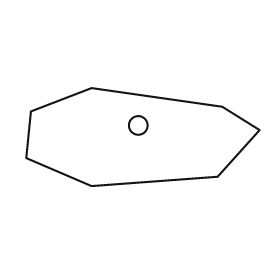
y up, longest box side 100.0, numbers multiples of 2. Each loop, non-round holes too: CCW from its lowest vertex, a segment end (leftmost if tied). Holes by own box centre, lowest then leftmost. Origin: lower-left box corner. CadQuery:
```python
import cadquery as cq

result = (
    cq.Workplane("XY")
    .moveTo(28.0, 0.0)
    .lineTo(82.0, 4.0)
    .lineTo(100.0, 24.0)
    .lineTo(84.0, 34.0)
    .lineTo(28.0, 42.0)
    .lineTo(2.0, 32.0)
    .lineTo(0.0, 12.0)
    .close()
    .moveTo(48.0, 26.0)
    .circle(4.0)
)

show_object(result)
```